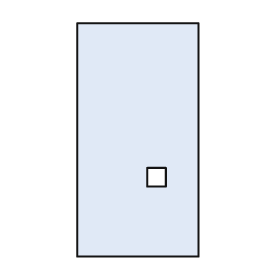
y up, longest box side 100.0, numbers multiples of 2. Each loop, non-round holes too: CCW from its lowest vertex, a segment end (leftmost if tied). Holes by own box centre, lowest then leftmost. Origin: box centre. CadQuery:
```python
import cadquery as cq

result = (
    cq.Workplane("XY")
    .moveTo(-26.0, -50.0)
    .lineTo(26.0, -50.0)
    .lineTo(26.0, 50.0)
    .lineTo(-26.0, 50.0)
    .close()
    .moveTo(4.0, -20.0)
    .lineTo(12.0, -20.0)
    .lineTo(12.0, -12.0)
    .lineTo(4.0, -12.0)
    .close()
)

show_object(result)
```